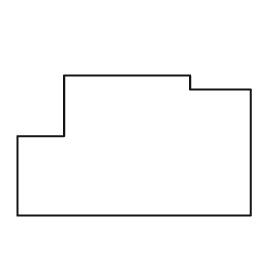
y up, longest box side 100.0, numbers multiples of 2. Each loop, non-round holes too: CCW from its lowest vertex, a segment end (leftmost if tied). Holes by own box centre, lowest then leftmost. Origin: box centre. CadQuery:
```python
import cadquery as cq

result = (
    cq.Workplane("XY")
    .moveTo(-50.0, -30.0)
    .lineTo(50.0, -30.0)
    .lineTo(50.0, 24.0)
    .lineTo(24.0, 24.0)
    .lineTo(24.0, 30.0)
    .lineTo(-30.0, 30.0)
    .lineTo(-30.0, 4.0)
    .lineTo(-50.0, 4.0)
    .close()
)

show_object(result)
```